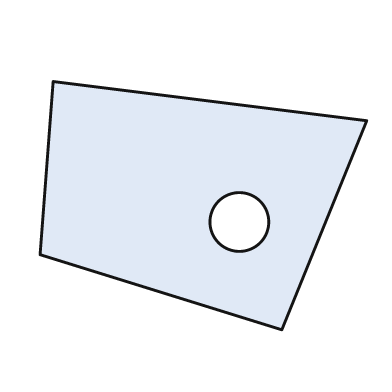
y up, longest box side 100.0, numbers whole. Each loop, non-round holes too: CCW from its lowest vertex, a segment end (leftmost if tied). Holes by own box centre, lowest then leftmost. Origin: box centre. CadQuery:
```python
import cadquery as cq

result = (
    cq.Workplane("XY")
    .moveTo(24.0, -38.0)
    .lineTo(50.0, 26.0)
    .lineTo(-46.0, 38.0)
    .lineTo(-50.0, -15.0)
    .close()
    .moveTo(11.0, -5.0)
    .circle(9.0)
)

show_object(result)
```